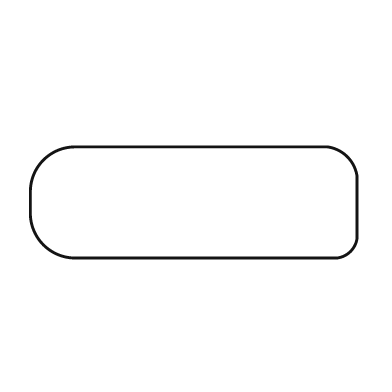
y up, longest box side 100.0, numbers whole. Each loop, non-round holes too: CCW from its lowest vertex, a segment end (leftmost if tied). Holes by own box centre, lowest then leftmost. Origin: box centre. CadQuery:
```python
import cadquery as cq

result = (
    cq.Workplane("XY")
    .moveTo(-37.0, -17.0)
    .lineTo(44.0, -17.0)
    .threePointArc((48.0, -15.0), (50.0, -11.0))
    .lineTo(50.0, 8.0)
    .threePointArc((47.0, 14.0), (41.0, 17.0))
    .lineTo(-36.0, 17.0)
    .threePointArc((-46.0, 13.0), (-50.0, 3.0))
    .lineTo(-50.0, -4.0)
    .threePointArc((-46.0, -13.0), (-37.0, -17.0))
    .close()
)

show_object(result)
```